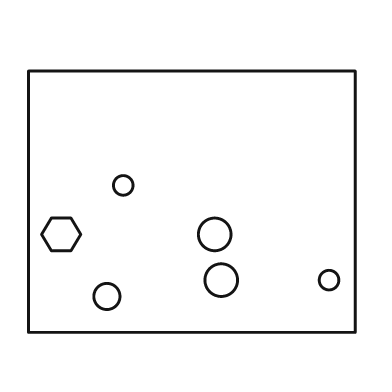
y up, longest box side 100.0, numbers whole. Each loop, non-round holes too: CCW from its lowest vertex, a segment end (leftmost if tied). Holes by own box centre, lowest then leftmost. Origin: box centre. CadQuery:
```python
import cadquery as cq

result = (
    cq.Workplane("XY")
    .moveTo(-50.0, -40.0)
    .lineTo(50.0, -40.0)
    .lineTo(50.0, 40.0)
    .lineTo(-50.0, 40.0)
    .close()
    .moveTo(-26.0, -29.0)
    .circle(4.0)
    .moveTo(9.0, -24.0)
    .circle(5.0)
    .moveTo(42.0, -24.0)
    .circle(3.0)
    .moveTo(-43.0, -15.0)
    .lineTo(-37.0, -15.0)
    .lineTo(-34.0, -10.0)
    .lineTo(-37.0, -5.0)
    .lineTo(-43.0, -5.0)
    .lineTo(-46.0, -10.0)
    .close()
    .moveTo(7.0, -10.0)
    .circle(5.0)
    .moveTo(-21.0, 5.0)
    .circle(3.0)
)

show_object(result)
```